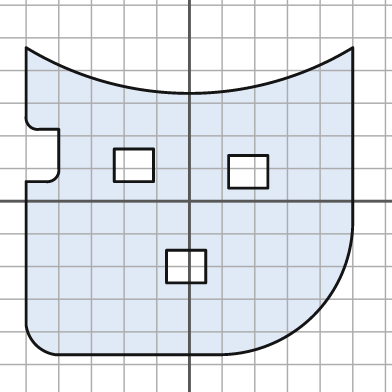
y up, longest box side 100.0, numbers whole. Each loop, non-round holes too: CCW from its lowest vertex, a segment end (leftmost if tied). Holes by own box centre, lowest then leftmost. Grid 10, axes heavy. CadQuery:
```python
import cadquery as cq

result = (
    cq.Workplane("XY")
    .moveTo(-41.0, -47.0)
    .lineTo(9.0, -47.0)
    .threePointArc((38.0, -35.0), (50.0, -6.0))
    .lineTo(50.0, 47.0)
    .threePointArc((0.0, 33.0), (-50.0, 47.0))
    .lineTo(-50.0, 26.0)
    .threePointArc((-49.0, 23.0), (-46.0, 22.0))
    .lineTo(-40.0, 22.0)
    .lineTo(-40.0, 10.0)
    .threePointArc((-41.0, 7.0), (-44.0, 6.0))
    .lineTo(-50.0, 6.0)
    .lineTo(-50.0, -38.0)
    .threePointArc((-47.0, -44.0), (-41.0, -47.0))
    .close()
    .moveTo(-7.0, -25.0)
    .lineTo(5.0, -25.0)
    .lineTo(5.0, -15.0)
    .lineTo(-7.0, -15.0)
    .close()
    .moveTo(12.0, 4.0)
    .lineTo(24.0, 4.0)
    .lineTo(24.0, 14.0)
    .lineTo(12.0, 14.0)
    .close()
    .moveTo(-23.0, 6.0)
    .lineTo(-11.0, 6.0)
    .lineTo(-11.0, 16.0)
    .lineTo(-23.0, 16.0)
    .close()
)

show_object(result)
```